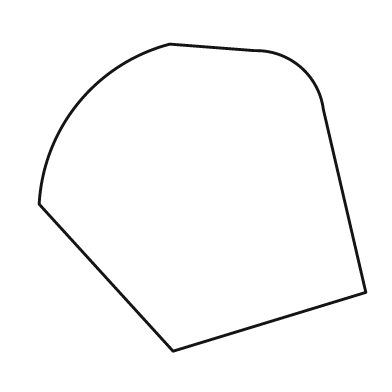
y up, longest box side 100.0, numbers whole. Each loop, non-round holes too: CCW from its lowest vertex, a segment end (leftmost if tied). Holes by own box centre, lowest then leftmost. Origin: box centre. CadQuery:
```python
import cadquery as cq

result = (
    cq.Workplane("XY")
    .moveTo(-9.0, -47.0)
    .lineTo(50.0, -29.0)
    .lineTo(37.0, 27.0)
    .threePointArc((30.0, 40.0), (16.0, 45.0))
    .lineTo(-10.0, 47.0)
    .threePointArc((-38.0, 29.0), (-50.0, -2.0))
    .close()
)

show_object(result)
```